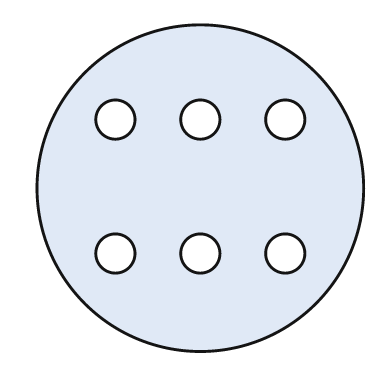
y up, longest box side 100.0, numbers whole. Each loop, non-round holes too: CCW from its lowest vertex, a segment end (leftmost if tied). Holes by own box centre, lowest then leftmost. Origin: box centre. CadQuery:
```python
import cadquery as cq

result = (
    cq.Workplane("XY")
    .moveTo(0.0, 0.0)
    .circle(50.0)
    .moveTo(-26.0, -20.0)
    .circle(6.0)
    .moveTo(0.0, -20.0)
    .circle(6.0)
    .moveTo(26.0, -20.0)
    .circle(6.0)
    .moveTo(-26.0, 21.0)
    .circle(6.0)
    .moveTo(0.0, 21.0)
    .circle(6.0)
    .moveTo(26.0, 21.0)
    .circle(6.0)
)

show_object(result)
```